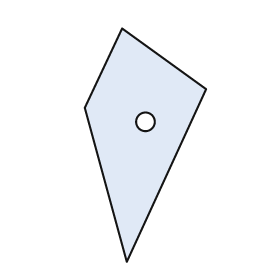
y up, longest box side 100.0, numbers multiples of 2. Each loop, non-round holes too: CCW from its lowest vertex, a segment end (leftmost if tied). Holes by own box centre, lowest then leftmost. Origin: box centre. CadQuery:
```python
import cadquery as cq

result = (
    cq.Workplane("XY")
    .moveTo(-8.0, -50.0)
    .lineTo(26.0, 24.0)
    .lineTo(-10.0, 50.0)
    .lineTo(-26.0, 16.0)
    .close()
    .moveTo(0.0, 10.0)
    .circle(4.0)
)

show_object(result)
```